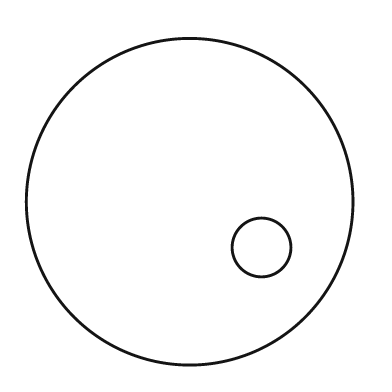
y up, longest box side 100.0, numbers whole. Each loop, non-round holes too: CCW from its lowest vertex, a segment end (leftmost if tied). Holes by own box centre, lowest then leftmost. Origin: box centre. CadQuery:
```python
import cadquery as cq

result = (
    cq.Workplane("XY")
    .moveTo(0.0, 0.0)
    .circle(50.0)
    .moveTo(22.0, -14.0)
    .circle(9.0)
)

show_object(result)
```